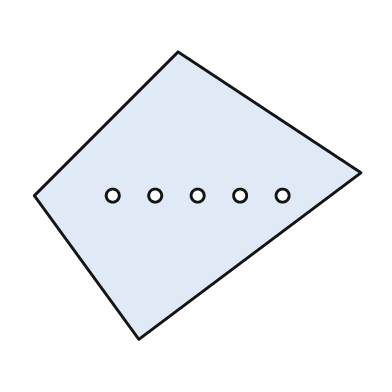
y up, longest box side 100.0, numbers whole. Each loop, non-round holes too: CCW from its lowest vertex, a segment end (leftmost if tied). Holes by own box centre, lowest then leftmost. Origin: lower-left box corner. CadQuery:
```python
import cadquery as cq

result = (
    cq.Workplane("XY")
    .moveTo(32.0, 0.0)
    .lineTo(100.0, 51.0)
    .lineTo(44.0, 88.0)
    .lineTo(0.0, 44.0)
    .close()
    .moveTo(24.0, 44.0)
    .circle(2.0)
    .moveTo(37.0, 44.0)
    .circle(2.0)
    .moveTo(50.0, 44.0)
    .circle(2.0)
    .moveTo(63.0, 44.0)
    .circle(2.0)
    .moveTo(76.0, 44.0)
    .circle(2.0)
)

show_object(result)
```